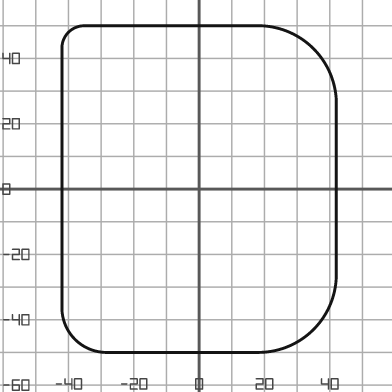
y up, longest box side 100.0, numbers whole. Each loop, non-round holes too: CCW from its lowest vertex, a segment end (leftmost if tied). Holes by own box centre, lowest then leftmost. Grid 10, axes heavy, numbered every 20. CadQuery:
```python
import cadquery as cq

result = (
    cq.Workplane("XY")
    .moveTo(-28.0, -50.0)
    .lineTo(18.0, -50.0)
    .threePointArc((35.0, -43.0), (42.0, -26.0))
    .lineTo(42.0, 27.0)
    .threePointArc((35.0, 43.0), (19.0, 50.0))
    .lineTo(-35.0, 50.0)
    .threePointArc((-40.0, 48.0), (-42.0, 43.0))
    .lineTo(-42.0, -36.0)
    .threePointArc((-38.0, -46.0), (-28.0, -50.0))
    .close()
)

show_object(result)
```